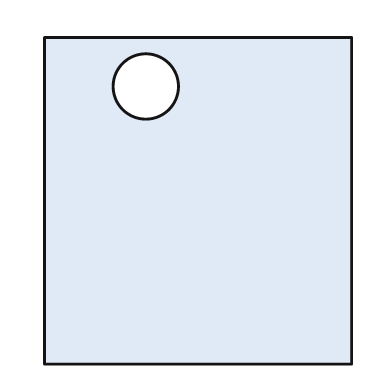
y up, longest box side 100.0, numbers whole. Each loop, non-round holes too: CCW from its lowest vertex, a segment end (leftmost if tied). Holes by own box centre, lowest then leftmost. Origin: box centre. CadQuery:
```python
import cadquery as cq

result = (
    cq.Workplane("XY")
    .moveTo(-47.0, -50.0)
    .lineTo(47.0, -50.0)
    .lineTo(47.0, 50.0)
    .lineTo(-47.0, 50.0)
    .close()
    .moveTo(-16.0, 35.0)
    .circle(10.0)
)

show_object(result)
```